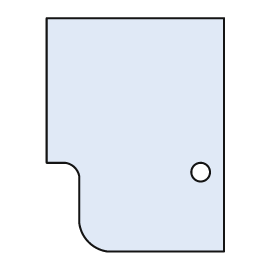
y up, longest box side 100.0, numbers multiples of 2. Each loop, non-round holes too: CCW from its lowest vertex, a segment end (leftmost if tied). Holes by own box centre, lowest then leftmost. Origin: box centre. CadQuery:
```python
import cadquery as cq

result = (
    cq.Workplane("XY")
    .moveTo(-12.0, -50.0)
    .lineTo(38.0, -50.0)
    .lineTo(38.0, 50.0)
    .lineTo(-38.0, 50.0)
    .lineTo(-38.0, -12.0)
    .lineTo(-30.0, -12.0)
    .threePointArc((-26.0, -14.0), (-24.0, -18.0))
    .lineTo(-24.0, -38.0)
    .threePointArc((-20.0, -46.0), (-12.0, -50.0))
    .close()
    .moveTo(28.0, -16.0)
    .circle(4.0)
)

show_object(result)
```